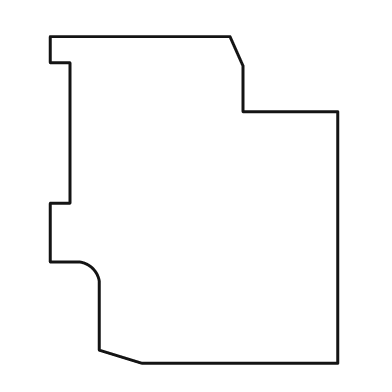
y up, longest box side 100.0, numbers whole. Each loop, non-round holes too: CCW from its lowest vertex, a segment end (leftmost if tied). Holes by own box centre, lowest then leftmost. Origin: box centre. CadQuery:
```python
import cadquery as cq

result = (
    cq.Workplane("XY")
    .moveTo(-16.0, -50.0)
    .lineTo(44.0, -50.0)
    .lineTo(44.0, 27.0)
    .lineTo(15.0, 27.0)
    .lineTo(15.0, 41.0)
    .lineTo(11.0, 50.0)
    .lineTo(-44.0, 50.0)
    .lineTo(-44.0, 42.0)
    .lineTo(-38.0, 42.0)
    .lineTo(-38.0, -1.0)
    .lineTo(-44.0, -1.0)
    .lineTo(-44.0, -19.0)
    .lineTo(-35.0, -19.0)
    .threePointArc((-31.0, -21.0), (-29.0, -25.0))
    .lineTo(-29.0, -46.0)
    .close()
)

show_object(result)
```